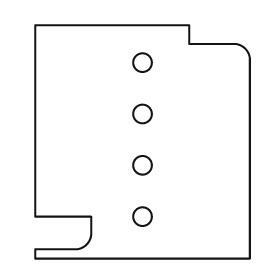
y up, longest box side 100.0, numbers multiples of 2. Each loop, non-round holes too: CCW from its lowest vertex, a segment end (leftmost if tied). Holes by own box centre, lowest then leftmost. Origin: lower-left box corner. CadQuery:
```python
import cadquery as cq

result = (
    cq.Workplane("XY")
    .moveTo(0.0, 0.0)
    .lineTo(92.0, 0.0)
    .lineTo(92.0, 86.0)
    .threePointArc((90.0, 90.0), (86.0, 92.0))
    .lineTo(66.0, 92.0)
    .lineTo(66.0, 100.0)
    .lineTo(0.0, 100.0)
    .lineTo(0.0, 18.0)
    .lineTo(24.0, 18.0)
    .lineTo(24.0, 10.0)
    .threePointArc((22.0, 6.0), (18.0, 4.0))
    .lineTo(0.0, 4.0)
    .close()
    .moveTo(46.0, 18.0)
    .circle(4.0)
    .moveTo(46.0, 40.0)
    .circle(4.0)
    .moveTo(46.0, 62.0)
    .circle(4.0)
    .moveTo(46.0, 84.0)
    .circle(4.0)
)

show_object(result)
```